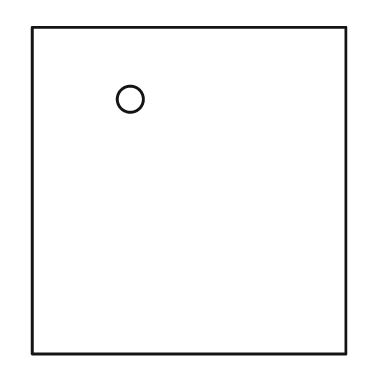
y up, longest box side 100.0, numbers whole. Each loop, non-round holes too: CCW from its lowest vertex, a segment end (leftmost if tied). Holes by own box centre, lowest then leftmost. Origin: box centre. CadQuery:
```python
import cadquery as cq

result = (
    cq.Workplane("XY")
    .moveTo(-48.0, -50.0)
    .lineTo(48.0, -50.0)
    .lineTo(48.0, 50.0)
    .lineTo(-48.0, 50.0)
    .close()
    .moveTo(-18.0, 28.0)
    .circle(4.0)
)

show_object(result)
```